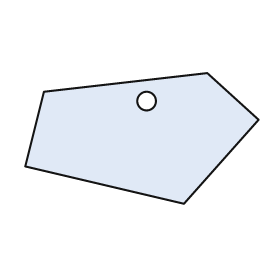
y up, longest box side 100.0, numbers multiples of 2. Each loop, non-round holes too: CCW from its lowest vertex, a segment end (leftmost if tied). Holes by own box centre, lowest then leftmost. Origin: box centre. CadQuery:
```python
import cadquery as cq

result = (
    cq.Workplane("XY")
    .moveTo(18.0, -28.0)
    .lineTo(50.0, 8.0)
    .lineTo(28.0, 28.0)
    .lineTo(-42.0, 20.0)
    .lineTo(-50.0, -12.0)
    .close()
    .moveTo(2.0, 16.0)
    .circle(4.0)
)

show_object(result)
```